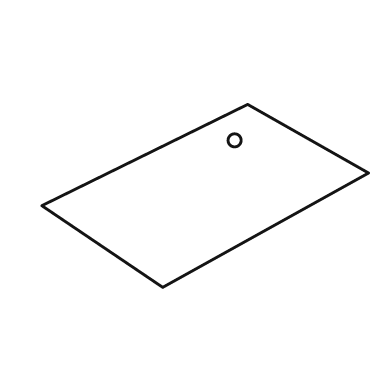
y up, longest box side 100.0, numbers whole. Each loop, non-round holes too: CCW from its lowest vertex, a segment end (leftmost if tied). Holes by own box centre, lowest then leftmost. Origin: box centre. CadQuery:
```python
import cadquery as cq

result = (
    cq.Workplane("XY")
    .moveTo(-13.0, -28.0)
    .lineTo(50.0, 7.0)
    .lineTo(13.0, 28.0)
    .lineTo(-50.0, -3.0)
    .close()
    .moveTo(9.0, 17.0)
    .circle(2.0)
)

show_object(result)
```